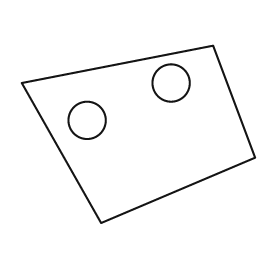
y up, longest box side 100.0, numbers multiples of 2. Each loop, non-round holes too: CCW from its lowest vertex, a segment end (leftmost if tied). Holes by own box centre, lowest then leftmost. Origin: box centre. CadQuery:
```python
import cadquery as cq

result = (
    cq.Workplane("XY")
    .moveTo(-16.0, -38.0)
    .lineTo(50.0, -10.0)
    .lineTo(32.0, 38.0)
    .lineTo(-50.0, 22.0)
    .close()
    .moveTo(-22.0, 6.0)
    .circle(8.0)
    .moveTo(14.0, 22.0)
    .circle(8.0)
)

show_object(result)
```